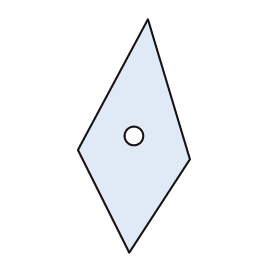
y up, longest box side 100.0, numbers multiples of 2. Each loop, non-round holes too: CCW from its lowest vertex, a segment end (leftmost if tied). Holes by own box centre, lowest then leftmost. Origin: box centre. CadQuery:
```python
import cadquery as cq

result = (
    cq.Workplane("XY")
    .moveTo(-2.0, -50.0)
    .lineTo(24.0, -10.0)
    .lineTo(6.0, 50.0)
    .lineTo(-24.0, -6.0)
    .close()
    .moveTo(0.0, 0.0)
    .circle(4.0)
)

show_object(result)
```